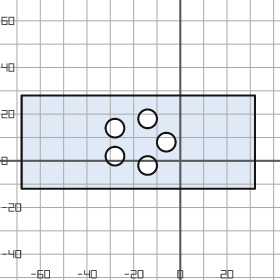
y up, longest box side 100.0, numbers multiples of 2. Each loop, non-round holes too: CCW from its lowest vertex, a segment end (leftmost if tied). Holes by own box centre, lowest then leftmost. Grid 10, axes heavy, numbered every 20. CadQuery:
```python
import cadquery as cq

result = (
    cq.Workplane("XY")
    .moveTo(-68.0, -12.0)
    .lineTo(32.0, -12.0)
    .lineTo(32.0, 28.0)
    .lineTo(-68.0, 28.0)
    .close()
    .moveTo(-14.0, -2.0)
    .circle(4.0)
    .moveTo(-28.0, 2.0)
    .circle(4.0)
    .moveTo(-6.0, 8.0)
    .circle(4.0)
    .moveTo(-28.0, 14.0)
    .circle(4.0)
    .moveTo(-14.0, 18.0)
    .circle(4.0)
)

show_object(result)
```